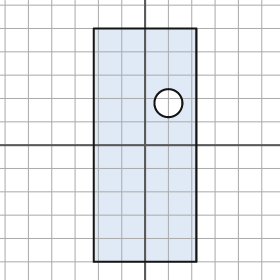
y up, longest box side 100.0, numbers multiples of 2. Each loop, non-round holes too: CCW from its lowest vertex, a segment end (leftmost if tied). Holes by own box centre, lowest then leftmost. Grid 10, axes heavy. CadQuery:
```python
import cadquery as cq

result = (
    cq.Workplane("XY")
    .moveTo(-22.0, -50.0)
    .lineTo(22.0, -50.0)
    .lineTo(22.0, 50.0)
    .lineTo(-22.0, 50.0)
    .close()
    .moveTo(10.0, 18.0)
    .circle(6.0)
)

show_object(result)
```